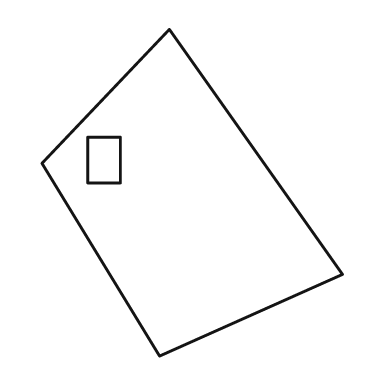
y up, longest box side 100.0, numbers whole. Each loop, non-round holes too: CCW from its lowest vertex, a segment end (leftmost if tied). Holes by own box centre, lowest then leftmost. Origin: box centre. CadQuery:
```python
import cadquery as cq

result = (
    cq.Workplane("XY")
    .moveTo(-10.0, -50.0)
    .lineTo(46.0, -25.0)
    .lineTo(-7.0, 50.0)
    .lineTo(-46.0, 9.0)
    .close()
    .moveTo(-32.0, 3.0)
    .lineTo(-22.0, 3.0)
    .lineTo(-22.0, 17.0)
    .lineTo(-32.0, 17.0)
    .close()
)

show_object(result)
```